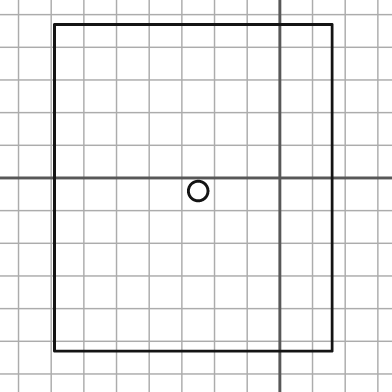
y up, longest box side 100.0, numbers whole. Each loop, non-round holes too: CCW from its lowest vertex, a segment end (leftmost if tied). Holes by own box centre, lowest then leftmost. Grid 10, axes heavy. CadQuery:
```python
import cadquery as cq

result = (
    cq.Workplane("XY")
    .moveTo(-69.0, -53.0)
    .lineTo(16.0, -53.0)
    .lineTo(16.0, 47.0)
    .lineTo(-69.0, 47.0)
    .close()
    .moveTo(-25.0, -4.0)
    .circle(3.0)
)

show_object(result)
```